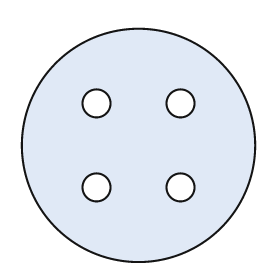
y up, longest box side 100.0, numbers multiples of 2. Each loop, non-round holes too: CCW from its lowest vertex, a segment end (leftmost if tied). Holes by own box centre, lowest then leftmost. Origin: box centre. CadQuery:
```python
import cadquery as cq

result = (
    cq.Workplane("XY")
    .moveTo(0.0, 0.0)
    .circle(50.0)
    .moveTo(-18.0, -18.0)
    .circle(6.0)
    .moveTo(18.0, -18.0)
    .circle(6.0)
    .moveTo(-18.0, 18.0)
    .circle(6.0)
    .moveTo(18.0, 18.0)
    .circle(6.0)
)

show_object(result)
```